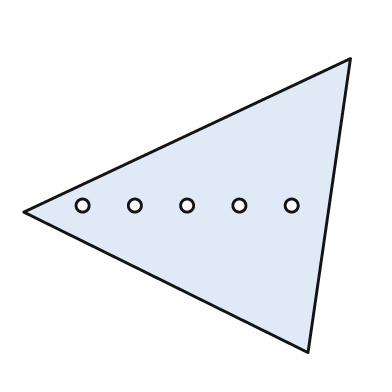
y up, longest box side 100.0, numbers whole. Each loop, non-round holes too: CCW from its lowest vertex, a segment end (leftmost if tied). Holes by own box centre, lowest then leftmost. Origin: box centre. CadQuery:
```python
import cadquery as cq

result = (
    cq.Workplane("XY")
    .moveTo(37.0, -45.0)
    .lineTo(50.0, 45.0)
    .lineTo(-50.0, -2.0)
    .close()
    .moveTo(-32.0, 0.0)
    .circle(2.0)
    .moveTo(-16.0, 0.0)
    .circle(2.0)
    .moveTo(0.0, 0.0)
    .circle(2.0)
    .moveTo(16.0, 0.0)
    .circle(2.0)
    .moveTo(32.0, 0.0)
    .circle(2.0)
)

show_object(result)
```